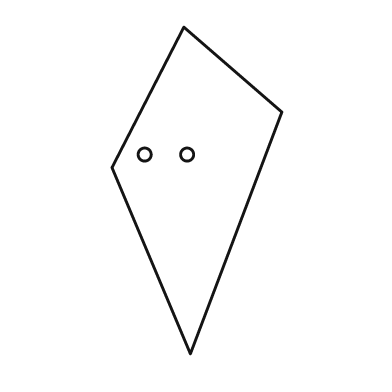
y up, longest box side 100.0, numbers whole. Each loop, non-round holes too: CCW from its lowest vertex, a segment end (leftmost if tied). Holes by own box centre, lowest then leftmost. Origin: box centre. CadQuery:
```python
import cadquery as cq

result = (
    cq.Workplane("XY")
    .moveTo(-2.0, -50.0)
    .lineTo(26.0, 24.0)
    .lineTo(-4.0, 50.0)
    .lineTo(-26.0, 7.0)
    .close()
    .moveTo(-16.0, 11.0)
    .circle(2.0)
    .moveTo(-3.0, 11.0)
    .circle(2.0)
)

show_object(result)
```